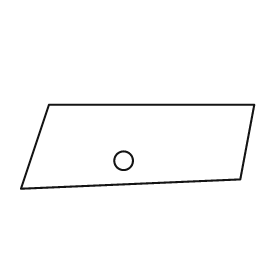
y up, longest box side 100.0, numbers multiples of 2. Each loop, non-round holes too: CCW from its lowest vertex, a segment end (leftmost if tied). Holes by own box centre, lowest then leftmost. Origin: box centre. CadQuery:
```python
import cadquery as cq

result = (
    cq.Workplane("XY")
    .moveTo(-50.0, -18.0)
    .lineTo(44.0, -14.0)
    .lineTo(50.0, 18.0)
    .lineTo(-38.0, 18.0)
    .close()
    .moveTo(-6.0, -6.0)
    .circle(4.0)
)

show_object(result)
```